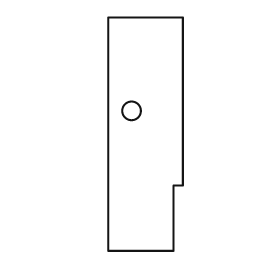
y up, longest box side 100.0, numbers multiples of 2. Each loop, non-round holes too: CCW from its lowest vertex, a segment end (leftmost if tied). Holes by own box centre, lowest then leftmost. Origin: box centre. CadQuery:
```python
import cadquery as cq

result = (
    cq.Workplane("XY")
    .moveTo(-16.0, -50.0)
    .lineTo(12.0, -50.0)
    .lineTo(12.0, -22.0)
    .lineTo(16.0, -22.0)
    .lineTo(16.0, 50.0)
    .lineTo(-16.0, 50.0)
    .close()
    .moveTo(-6.0, 10.0)
    .circle(4.0)
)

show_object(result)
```